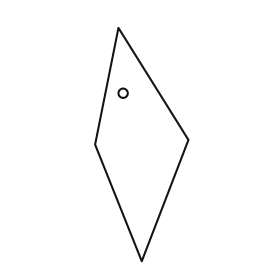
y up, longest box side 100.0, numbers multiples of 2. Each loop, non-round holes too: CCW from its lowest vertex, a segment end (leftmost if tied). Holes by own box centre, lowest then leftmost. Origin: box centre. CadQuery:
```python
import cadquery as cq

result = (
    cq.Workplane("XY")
    .moveTo(0.0, -50.0)
    .lineTo(20.0, 2.0)
    .lineTo(-10.0, 50.0)
    .lineTo(-20.0, 0.0)
    .close()
    .moveTo(-8.0, 22.0)
    .circle(2.0)
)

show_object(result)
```